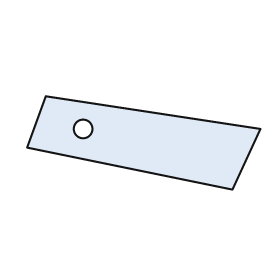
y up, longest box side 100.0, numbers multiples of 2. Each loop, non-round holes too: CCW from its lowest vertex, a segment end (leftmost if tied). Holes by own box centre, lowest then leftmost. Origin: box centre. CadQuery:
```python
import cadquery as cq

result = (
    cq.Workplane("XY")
    .moveTo(38.0, -20.0)
    .lineTo(50.0, 6.0)
    .lineTo(-42.0, 20.0)
    .lineTo(-50.0, -2.0)
    .close()
    .moveTo(-26.0, 6.0)
    .circle(4.0)
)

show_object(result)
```